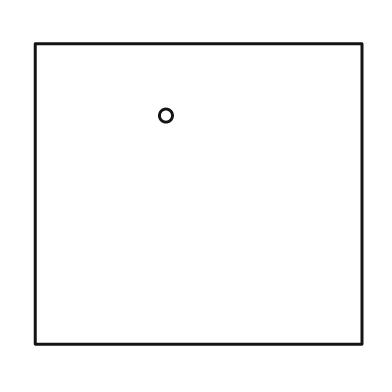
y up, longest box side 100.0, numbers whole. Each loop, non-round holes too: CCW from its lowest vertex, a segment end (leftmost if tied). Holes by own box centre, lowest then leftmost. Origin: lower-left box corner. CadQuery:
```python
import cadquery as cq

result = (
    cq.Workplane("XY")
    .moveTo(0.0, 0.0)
    .lineTo(100.0, 0.0)
    .lineTo(100.0, 92.0)
    .lineTo(0.0, 92.0)
    .close()
    .moveTo(40.0, 70.0)
    .circle(2.0)
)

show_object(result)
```